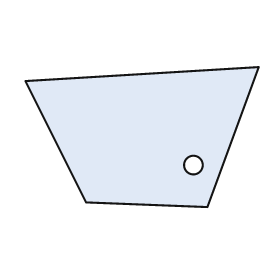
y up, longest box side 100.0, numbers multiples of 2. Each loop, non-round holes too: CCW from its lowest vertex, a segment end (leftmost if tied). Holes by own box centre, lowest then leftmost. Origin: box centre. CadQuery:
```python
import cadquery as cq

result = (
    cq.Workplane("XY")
    .moveTo(28.0, -30.0)
    .lineTo(50.0, 30.0)
    .lineTo(-50.0, 24.0)
    .lineTo(-24.0, -28.0)
    .close()
    .moveTo(22.0, -12.0)
    .circle(4.0)
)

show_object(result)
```